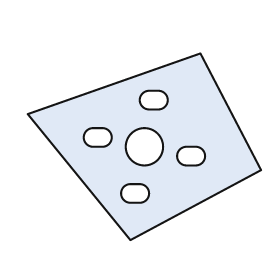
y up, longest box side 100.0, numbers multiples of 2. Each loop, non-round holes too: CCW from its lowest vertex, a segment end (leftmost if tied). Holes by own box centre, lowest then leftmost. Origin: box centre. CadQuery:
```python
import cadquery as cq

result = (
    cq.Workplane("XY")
    .moveTo(-6.0, -40.0)
    .lineTo(50.0, -10.0)
    .lineTo(24.0, 40.0)
    .lineTo(-50.0, 14.0)
    .close()
    .moveTo(-6.0, -24.0)
    .lineTo(-2.0, -24.0)
    .threePointArc((2.0, -20.0), (-2.0, -16.0))
    .lineTo(-6.0, -16.0)
    .threePointArc((-10.0, -20.0), (-6.0, -24.0))
    .close()
    .moveTo(18.0, -8.0)
    .lineTo(22.0, -8.0)
    .threePointArc((26.0, -4.0), (22.0, 0.0))
    .lineTo(18.0, 0.0)
    .threePointArc((14.0, -4.0), (18.0, -8.0))
    .close()
    .moveTo(0.0, 0.0)
    .circle(8.0)
    .moveTo(-22.0, 0.0)
    .lineTo(-18.0, 0.0)
    .threePointArc((-14.0, 4.0), (-18.0, 8.0))
    .lineTo(-22.0, 8.0)
    .threePointArc((-26.0, 4.0), (-22.0, 0.0))
    .close()
    .moveTo(2.0, 16.0)
    .lineTo(6.0, 16.0)
    .threePointArc((10.0, 20.0), (6.0, 24.0))
    .lineTo(2.0, 24.0)
    .threePointArc((-2.0, 20.0), (2.0, 16.0))
    .close()
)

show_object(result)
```